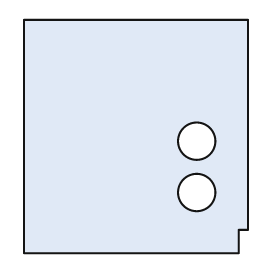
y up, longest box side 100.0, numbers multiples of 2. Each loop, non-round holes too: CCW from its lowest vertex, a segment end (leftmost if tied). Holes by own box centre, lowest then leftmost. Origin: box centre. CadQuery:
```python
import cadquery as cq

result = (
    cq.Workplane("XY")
    .moveTo(-48.0, -50.0)
    .lineTo(44.0, -50.0)
    .lineTo(44.0, -40.0)
    .lineTo(48.0, -40.0)
    .lineTo(48.0, 50.0)
    .lineTo(-48.0, 50.0)
    .close()
    .moveTo(26.0, -24.0)
    .circle(8.0)
    .moveTo(26.0, -2.0)
    .circle(8.0)
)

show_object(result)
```